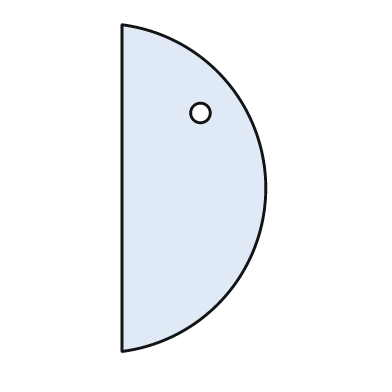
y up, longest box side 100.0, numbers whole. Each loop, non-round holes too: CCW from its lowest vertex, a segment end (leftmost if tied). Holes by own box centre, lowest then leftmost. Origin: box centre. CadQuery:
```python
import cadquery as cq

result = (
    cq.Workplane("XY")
    .moveTo(-22.0, -50.0)
    .threePointArc((22.0, 0.0), (-22.0, 50.0))
    .close()
    .moveTo(2.0, 23.0)
    .circle(3.0)
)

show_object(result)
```